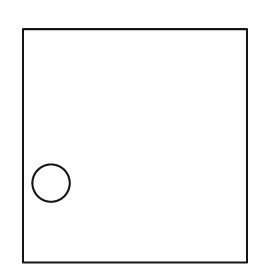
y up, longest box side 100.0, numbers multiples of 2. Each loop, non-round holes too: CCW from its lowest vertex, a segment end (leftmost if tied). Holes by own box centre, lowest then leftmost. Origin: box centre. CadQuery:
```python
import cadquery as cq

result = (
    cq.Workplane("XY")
    .moveTo(-48.0, -50.0)
    .lineTo(48.0, -50.0)
    .lineTo(48.0, 50.0)
    .lineTo(-48.0, 50.0)
    .close()
    .moveTo(-36.0, -16.0)
    .circle(8.0)
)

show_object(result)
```